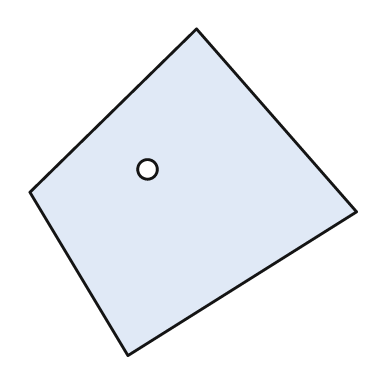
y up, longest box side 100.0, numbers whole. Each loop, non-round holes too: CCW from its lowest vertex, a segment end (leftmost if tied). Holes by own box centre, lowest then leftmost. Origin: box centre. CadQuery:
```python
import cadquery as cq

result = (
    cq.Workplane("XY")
    .moveTo(-20.0, -50.0)
    .lineTo(50.0, -6.0)
    .lineTo(1.0, 50.0)
    .lineTo(-50.0, 0.0)
    .close()
    .moveTo(-14.0, 7.0)
    .circle(3.0)
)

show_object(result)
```